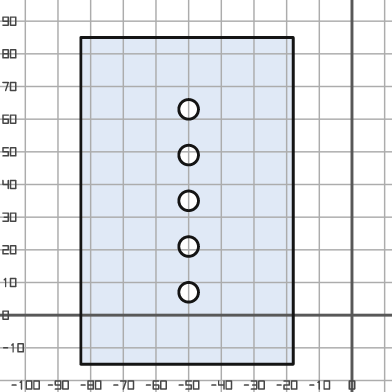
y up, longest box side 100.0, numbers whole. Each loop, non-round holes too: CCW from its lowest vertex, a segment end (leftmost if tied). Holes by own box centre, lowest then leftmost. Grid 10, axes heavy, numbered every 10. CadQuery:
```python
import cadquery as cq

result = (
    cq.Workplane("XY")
    .moveTo(-83.0, -15.0)
    .lineTo(-18.0, -15.0)
    .lineTo(-18.0, 85.0)
    .lineTo(-83.0, 85.0)
    .close()
    .moveTo(-50.0, 7.0)
    .circle(3.0)
    .moveTo(-50.0, 21.0)
    .circle(3.0)
    .moveTo(-50.0, 35.0)
    .circle(3.0)
    .moveTo(-50.0, 49.0)
    .circle(3.0)
    .moveTo(-50.0, 63.0)
    .circle(3.0)
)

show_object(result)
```